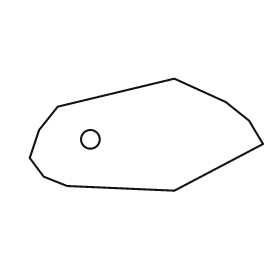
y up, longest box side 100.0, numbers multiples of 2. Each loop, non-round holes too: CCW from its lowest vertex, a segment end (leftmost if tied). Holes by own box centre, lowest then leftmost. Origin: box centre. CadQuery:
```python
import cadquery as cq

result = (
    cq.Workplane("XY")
    .moveTo(12.0, -24.0)
    .lineTo(50.0, -4.0)
    .lineTo(44.0, 6.0)
    .lineTo(34.0, 14.0)
    .lineTo(12.0, 24.0)
    .lineTo(-38.0, 12.0)
    .lineTo(-46.0, 2.0)
    .lineTo(-50.0, -10.0)
    .lineTo(-44.0, -18.0)
    .lineTo(-34.0, -22.0)
    .close()
    .moveTo(-24.0, -2.0)
    .circle(4.0)
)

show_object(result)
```